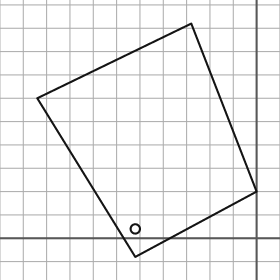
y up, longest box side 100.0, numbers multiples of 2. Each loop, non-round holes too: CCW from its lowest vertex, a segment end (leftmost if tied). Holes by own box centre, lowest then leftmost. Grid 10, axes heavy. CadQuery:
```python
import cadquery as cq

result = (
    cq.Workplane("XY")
    .moveTo(-52.0, -8.0)
    .lineTo(0.0, 20.0)
    .lineTo(-28.0, 92.0)
    .lineTo(-94.0, 60.0)
    .close()
    .moveTo(-52.0, 4.0)
    .circle(2.0)
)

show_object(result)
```